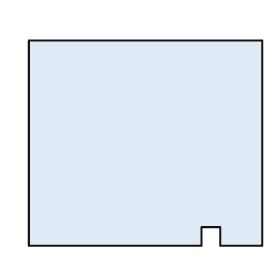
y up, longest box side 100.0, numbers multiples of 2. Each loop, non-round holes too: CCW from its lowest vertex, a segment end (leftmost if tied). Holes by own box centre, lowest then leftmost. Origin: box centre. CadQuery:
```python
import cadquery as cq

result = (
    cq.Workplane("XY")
    .moveTo(-50.0, -44.0)
    .lineTo(24.0, -44.0)
    .lineTo(24.0, -36.0)
    .lineTo(32.0, -36.0)
    .lineTo(32.0, -44.0)
    .lineTo(50.0, -44.0)
    .lineTo(50.0, 44.0)
    .lineTo(-50.0, 44.0)
    .close()
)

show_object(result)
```